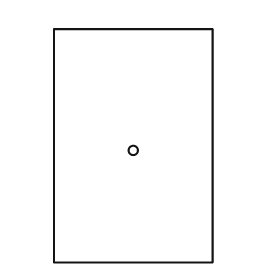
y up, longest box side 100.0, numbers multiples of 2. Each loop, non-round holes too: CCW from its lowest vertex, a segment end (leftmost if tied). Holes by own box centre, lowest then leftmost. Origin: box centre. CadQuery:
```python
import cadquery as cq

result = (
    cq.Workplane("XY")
    .moveTo(-34.0, -50.0)
    .lineTo(34.0, -50.0)
    .lineTo(34.0, 50.0)
    .lineTo(-34.0, 50.0)
    .close()
    .moveTo(0.0, -2.0)
    .circle(2.0)
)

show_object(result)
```